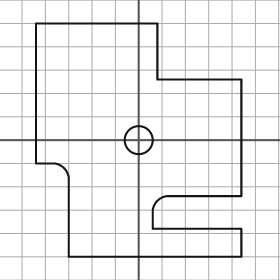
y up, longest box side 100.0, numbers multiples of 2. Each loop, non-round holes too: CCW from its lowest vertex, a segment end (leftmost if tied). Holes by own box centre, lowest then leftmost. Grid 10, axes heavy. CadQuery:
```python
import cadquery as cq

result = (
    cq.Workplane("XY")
    .moveTo(-30.0, -50.0)
    .lineTo(44.0, -50.0)
    .lineTo(44.0, -38.0)
    .lineTo(6.0, -38.0)
    .lineTo(6.0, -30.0)
    .threePointArc((8.0, -26.0), (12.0, -24.0))
    .lineTo(44.0, -24.0)
    .lineTo(44.0, 26.0)
    .lineTo(8.0, 26.0)
    .lineTo(8.0, 50.0)
    .lineTo(-44.0, 50.0)
    .lineTo(-44.0, -10.0)
    .lineTo(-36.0, -10.0)
    .threePointArc((-32.0, -12.0), (-30.0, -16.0))
    .close()
    .moveTo(0.0, 0.0)
    .circle(6.0)
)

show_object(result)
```